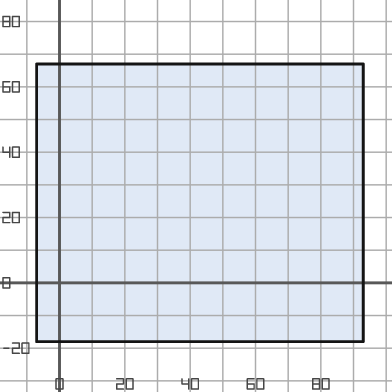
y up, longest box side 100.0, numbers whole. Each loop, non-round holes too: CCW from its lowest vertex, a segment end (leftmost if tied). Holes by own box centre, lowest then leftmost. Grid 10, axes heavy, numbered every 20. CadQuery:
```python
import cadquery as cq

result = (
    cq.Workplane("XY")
    .moveTo(-7.0, -18.0)
    .lineTo(93.0, -18.0)
    .lineTo(93.0, 67.0)
    .lineTo(-7.0, 67.0)
    .close()
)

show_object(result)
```